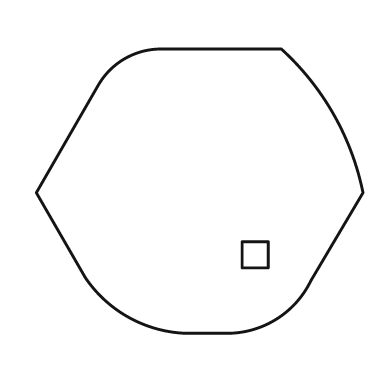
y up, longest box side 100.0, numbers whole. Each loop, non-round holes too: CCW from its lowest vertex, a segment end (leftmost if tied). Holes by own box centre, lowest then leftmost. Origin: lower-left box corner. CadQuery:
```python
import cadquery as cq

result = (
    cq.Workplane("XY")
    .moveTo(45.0, 0.0)
    .lineTo(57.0, 0.0)
    .threePointArc((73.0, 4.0), (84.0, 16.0))
    .lineTo(100.0, 43.0)
    .threePointArc((91.0, 67.0), (75.0, 87.0))
    .lineTo(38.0, 87.0)
    .threePointArc((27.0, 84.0), (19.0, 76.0))
    .lineTo(0.0, 43.0)
    .lineTo(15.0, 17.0)
    .threePointArc((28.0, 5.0), (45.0, 0.0))
    .close()
    .moveTo(63.0, 20.0)
    .lineTo(71.0, 20.0)
    .lineTo(71.0, 28.0)
    .lineTo(63.0, 28.0)
    .close()
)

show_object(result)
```